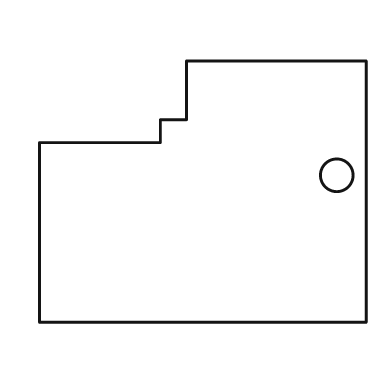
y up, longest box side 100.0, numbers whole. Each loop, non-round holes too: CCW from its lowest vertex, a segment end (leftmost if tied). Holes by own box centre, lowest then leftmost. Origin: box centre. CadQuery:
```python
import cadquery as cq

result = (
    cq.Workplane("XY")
    .moveTo(-50.0, -40.0)
    .lineTo(50.0, -40.0)
    .lineTo(50.0, 40.0)
    .lineTo(-5.0, 40.0)
    .lineTo(-5.0, 22.0)
    .lineTo(-13.0, 22.0)
    .lineTo(-13.0, 15.0)
    .lineTo(-50.0, 15.0)
    .close()
    .moveTo(41.0, 5.0)
    .circle(5.0)
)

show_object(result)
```